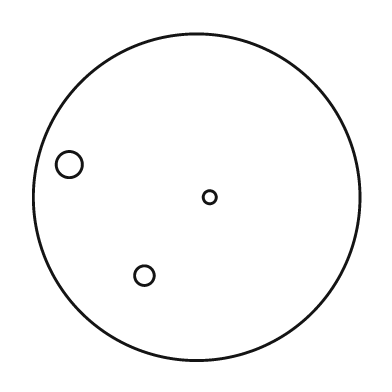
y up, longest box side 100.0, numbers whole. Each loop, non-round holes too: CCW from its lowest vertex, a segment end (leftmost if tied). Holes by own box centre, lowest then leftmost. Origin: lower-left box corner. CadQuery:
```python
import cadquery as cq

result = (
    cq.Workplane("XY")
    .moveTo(50.0, 50.0)
    .circle(50.0)
    .moveTo(34.0, 26.0)
    .circle(3.0)
    .moveTo(54.0, 50.0)
    .circle(2.0)
    .moveTo(11.0, 60.0)
    .circle(4.0)
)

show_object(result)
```